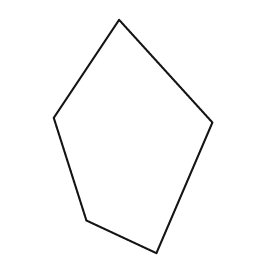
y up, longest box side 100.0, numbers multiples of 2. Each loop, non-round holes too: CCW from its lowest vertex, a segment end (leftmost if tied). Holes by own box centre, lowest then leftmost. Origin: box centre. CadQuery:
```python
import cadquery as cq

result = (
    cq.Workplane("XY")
    .moveTo(10.0, -50.0)
    .lineTo(34.0, 6.0)
    .lineTo(-6.0, 50.0)
    .lineTo(-34.0, 8.0)
    .lineTo(-20.0, -36.0)
    .close()
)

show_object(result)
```